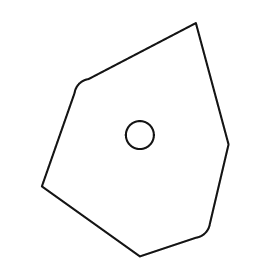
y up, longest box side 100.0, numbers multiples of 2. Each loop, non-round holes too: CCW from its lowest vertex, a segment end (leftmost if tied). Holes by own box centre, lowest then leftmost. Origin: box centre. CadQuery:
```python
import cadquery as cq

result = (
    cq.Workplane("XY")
    .moveTo(2.0, -50.0)
    .lineTo(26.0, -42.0)
    .threePointArc((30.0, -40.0), (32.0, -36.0))
    .lineTo(40.0, -2.0)
    .lineTo(26.0, 50.0)
    .lineTo(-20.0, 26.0)
    .threePointArc((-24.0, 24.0), (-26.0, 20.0))
    .lineTo(-40.0, -20.0)
    .close()
    .moveTo(2.0, 2.0)
    .circle(6.0)
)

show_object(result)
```